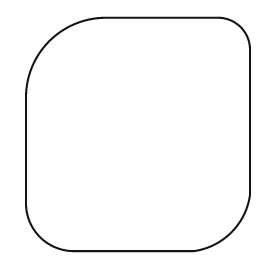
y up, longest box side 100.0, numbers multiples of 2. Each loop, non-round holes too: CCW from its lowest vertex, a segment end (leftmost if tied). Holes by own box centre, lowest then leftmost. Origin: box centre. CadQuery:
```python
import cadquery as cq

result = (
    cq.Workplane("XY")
    .moveTo(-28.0, -50.0)
    .lineTo(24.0, -50.0)
    .threePointArc((40.0, -42.0), (48.0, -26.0))
    .lineTo(48.0, 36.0)
    .threePointArc((44.0, 46.0), (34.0, 50.0))
    .lineTo(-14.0, 50.0)
    .threePointArc((-38.0, 40.0), (-48.0, 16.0))
    .lineTo(-48.0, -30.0)
    .threePointArc((-42.0, -44.0), (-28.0, -50.0))
    .close()
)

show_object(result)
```